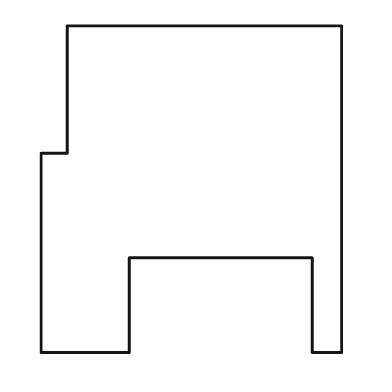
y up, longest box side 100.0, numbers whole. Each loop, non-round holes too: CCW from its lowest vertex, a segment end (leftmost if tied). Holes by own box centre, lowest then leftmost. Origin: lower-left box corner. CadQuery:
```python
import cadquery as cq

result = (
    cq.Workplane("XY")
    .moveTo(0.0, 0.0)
    .lineTo(27.0, 0.0)
    .lineTo(27.0, 29.0)
    .lineTo(83.0, 29.0)
    .lineTo(83.0, 0.0)
    .lineTo(92.0, 0.0)
    .lineTo(92.0, 100.0)
    .lineTo(8.0, 100.0)
    .lineTo(8.0, 61.0)
    .lineTo(0.0, 61.0)
    .close()
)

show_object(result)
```